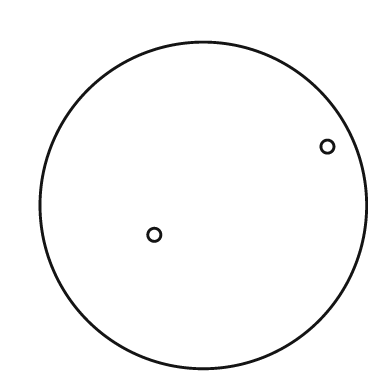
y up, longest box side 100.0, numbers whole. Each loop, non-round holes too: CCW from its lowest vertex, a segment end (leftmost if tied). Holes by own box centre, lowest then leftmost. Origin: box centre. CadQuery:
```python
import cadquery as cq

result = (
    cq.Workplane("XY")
    .moveTo(0.0, 0.0)
    .circle(50.0)
    .moveTo(-15.0, -9.0)
    .circle(2.0)
    .moveTo(38.0, 18.0)
    .circle(2.0)
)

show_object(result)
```